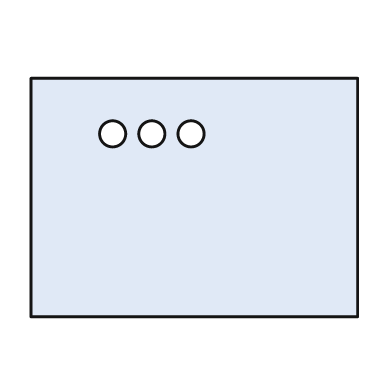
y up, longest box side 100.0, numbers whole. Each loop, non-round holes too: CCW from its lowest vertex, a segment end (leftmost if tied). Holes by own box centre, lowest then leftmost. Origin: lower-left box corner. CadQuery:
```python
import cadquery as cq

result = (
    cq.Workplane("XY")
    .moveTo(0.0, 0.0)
    .lineTo(100.0, 0.0)
    .lineTo(100.0, 73.0)
    .lineTo(0.0, 73.0)
    .close()
    .moveTo(25.0, 56.0)
    .circle(4.0)
    .moveTo(37.0, 56.0)
    .circle(4.0)
    .moveTo(49.0, 56.0)
    .circle(4.0)
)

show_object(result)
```